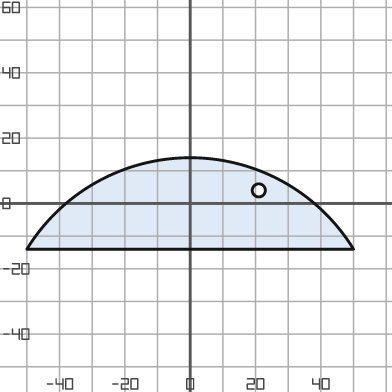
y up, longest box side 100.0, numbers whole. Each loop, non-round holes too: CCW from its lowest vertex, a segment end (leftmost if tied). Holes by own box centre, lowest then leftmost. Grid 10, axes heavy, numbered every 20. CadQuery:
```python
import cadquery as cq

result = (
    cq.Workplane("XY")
    .moveTo(-50.0, -14.0)
    .lineTo(50.0, -14.0)
    .threePointArc((0.0, 14.0), (-50.0, -14.0))
    .close()
    .moveTo(21.0, 4.0)
    .circle(2.0)
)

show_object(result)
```